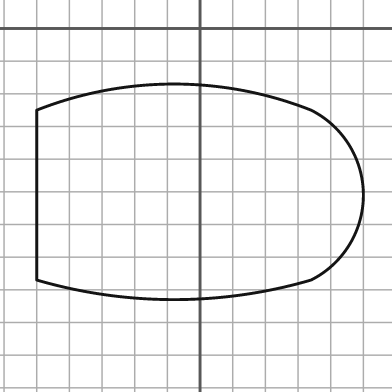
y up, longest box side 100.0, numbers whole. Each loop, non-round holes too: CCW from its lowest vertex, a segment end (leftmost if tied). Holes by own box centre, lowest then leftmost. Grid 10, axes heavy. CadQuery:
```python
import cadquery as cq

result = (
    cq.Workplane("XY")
    .moveTo(-50.0, -77.0)
    .threePointArc((-8.0, -83.0), (34.0, -77.0))
    .threePointArc((50.0, -51.0), (34.0, -25.0))
    .threePointArc((-8.0, -17.0), (-50.0, -25.0))
    .close()
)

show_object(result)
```